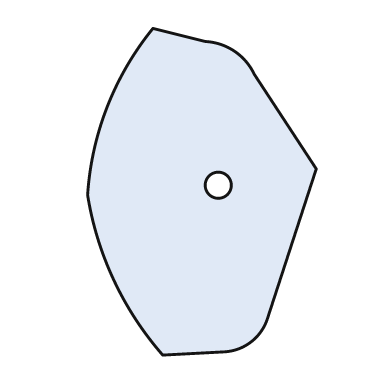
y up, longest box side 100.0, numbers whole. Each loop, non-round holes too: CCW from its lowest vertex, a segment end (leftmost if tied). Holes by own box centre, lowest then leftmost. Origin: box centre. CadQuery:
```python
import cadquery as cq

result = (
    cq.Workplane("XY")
    .moveTo(-12.0, -50.0)
    .lineTo(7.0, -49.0)
    .threePointArc((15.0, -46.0), (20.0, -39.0))
    .lineTo(35.0, 7.0)
    .lineTo(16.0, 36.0)
    .threePointArc((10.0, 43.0), (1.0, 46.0))
    .lineTo(-15.0, 50.0)
    .threePointArc((-29.0, 26.0), (-35.0, -1.0))
    .threePointArc((-27.0, -27.0), (-12.0, -50.0))
    .close()
    .moveTo(5.0, 2.0)
    .circle(4.0)
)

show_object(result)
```